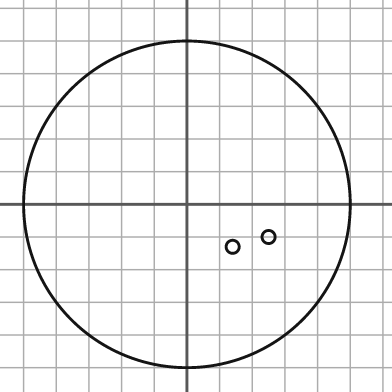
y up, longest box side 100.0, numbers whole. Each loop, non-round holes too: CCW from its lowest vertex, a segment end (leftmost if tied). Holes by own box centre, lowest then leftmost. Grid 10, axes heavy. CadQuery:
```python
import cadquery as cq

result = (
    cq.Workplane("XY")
    .moveTo(0.0, 0.0)
    .circle(50.0)
    .moveTo(14.0, -13.0)
    .circle(2.0)
    .moveTo(25.0, -10.0)
    .circle(2.0)
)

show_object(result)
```